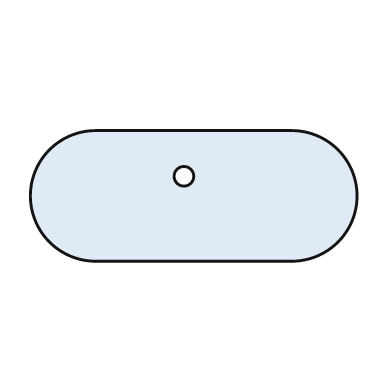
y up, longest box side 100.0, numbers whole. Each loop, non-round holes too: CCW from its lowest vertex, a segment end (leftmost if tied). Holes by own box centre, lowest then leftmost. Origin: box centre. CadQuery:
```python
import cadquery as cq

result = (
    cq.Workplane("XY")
    .moveTo(-30.0, -20.0)
    .lineTo(30.0, -20.0)
    .threePointArc((50.0, 0.0), (30.0, 20.0))
    .lineTo(-30.0, 20.0)
    .threePointArc((-50.0, 0.0), (-30.0, -20.0))
    .close()
    .moveTo(-3.0, 6.0)
    .circle(3.0)
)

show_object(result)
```